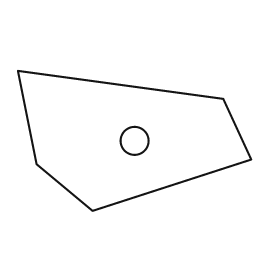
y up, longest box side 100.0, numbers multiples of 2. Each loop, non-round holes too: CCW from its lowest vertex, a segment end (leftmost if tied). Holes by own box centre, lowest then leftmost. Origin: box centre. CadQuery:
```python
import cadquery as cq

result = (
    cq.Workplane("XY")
    .moveTo(-18.0, -30.0)
    .lineTo(50.0, -8.0)
    .lineTo(38.0, 18.0)
    .lineTo(-50.0, 30.0)
    .lineTo(-42.0, -10.0)
    .close()
    .moveTo(0.0, 0.0)
    .circle(6.0)
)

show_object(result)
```